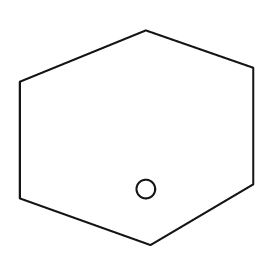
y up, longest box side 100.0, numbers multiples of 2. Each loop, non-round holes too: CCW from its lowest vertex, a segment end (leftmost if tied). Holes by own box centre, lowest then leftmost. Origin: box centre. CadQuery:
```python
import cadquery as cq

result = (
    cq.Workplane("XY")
    .moveTo(6.0, -46.0)
    .lineTo(50.0, -20.0)
    .lineTo(50.0, 30.0)
    .lineTo(4.0, 46.0)
    .lineTo(-50.0, 24.0)
    .lineTo(-50.0, -26.0)
    .close()
    .moveTo(4.0, -22.0)
    .circle(4.0)
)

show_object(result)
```